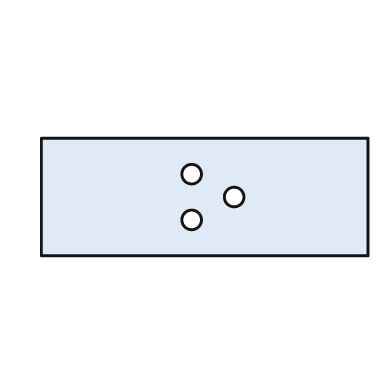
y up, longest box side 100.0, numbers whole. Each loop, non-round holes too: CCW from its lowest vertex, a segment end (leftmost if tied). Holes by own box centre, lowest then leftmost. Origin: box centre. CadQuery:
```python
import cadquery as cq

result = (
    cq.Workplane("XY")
    .moveTo(-50.0, -18.0)
    .lineTo(50.0, -18.0)
    .lineTo(50.0, 18.0)
    .lineTo(-50.0, 18.0)
    .close()
    .moveTo(-4.0, -7.0)
    .circle(3.0)
    .moveTo(9.0, 0.0)
    .circle(3.0)
    .moveTo(-4.0, 7.0)
    .circle(3.0)
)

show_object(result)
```